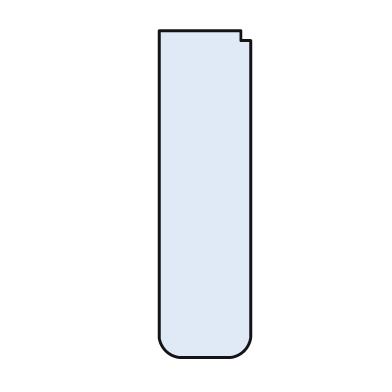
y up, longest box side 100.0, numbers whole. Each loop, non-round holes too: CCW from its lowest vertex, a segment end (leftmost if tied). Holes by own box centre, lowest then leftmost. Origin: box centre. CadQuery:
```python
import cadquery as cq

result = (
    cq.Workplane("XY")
    .moveTo(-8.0, -50.0)
    .lineTo(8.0, -50.0)
    .threePointArc((12.0, -48.0), (14.0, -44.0))
    .lineTo(14.0, 47.0)
    .lineTo(11.0, 47.0)
    .lineTo(11.0, 50.0)
    .lineTo(-14.0, 50.0)
    .lineTo(-14.0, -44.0)
    .threePointArc((-12.0, -48.0), (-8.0, -50.0))
    .close()
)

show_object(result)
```